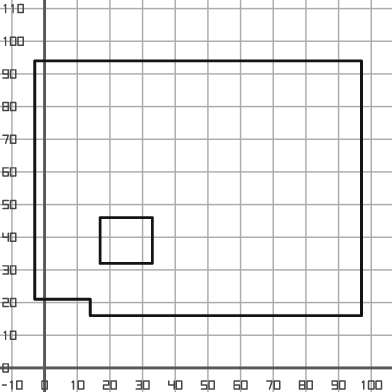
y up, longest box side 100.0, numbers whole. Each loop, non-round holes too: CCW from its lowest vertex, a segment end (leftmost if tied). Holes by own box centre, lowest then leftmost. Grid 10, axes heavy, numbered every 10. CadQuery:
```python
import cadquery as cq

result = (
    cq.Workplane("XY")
    .moveTo(14.0, 16.0)
    .lineTo(97.0, 16.0)
    .lineTo(97.0, 94.0)
    .lineTo(-3.0, 94.0)
    .lineTo(-3.0, 21.0)
    .lineTo(14.0, 21.0)
    .close()
    .moveTo(17.0, 32.0)
    .lineTo(33.0, 32.0)
    .lineTo(33.0, 46.0)
    .lineTo(17.0, 46.0)
    .close()
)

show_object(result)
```